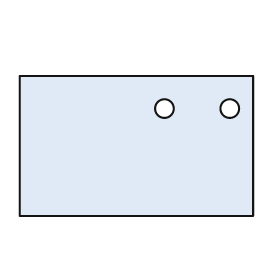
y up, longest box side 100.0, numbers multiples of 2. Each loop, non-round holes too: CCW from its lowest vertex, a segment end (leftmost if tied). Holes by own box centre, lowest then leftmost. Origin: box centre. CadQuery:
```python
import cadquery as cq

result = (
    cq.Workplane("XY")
    .moveTo(-50.0, -30.0)
    .lineTo(50.0, -30.0)
    .lineTo(50.0, 30.0)
    .lineTo(-50.0, 30.0)
    .close()
    .moveTo(12.0, 16.0)
    .circle(4.0)
    .moveTo(40.0, 16.0)
    .circle(4.0)
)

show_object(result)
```